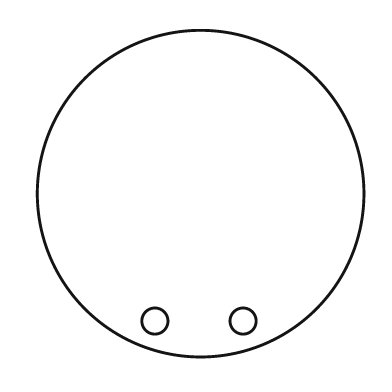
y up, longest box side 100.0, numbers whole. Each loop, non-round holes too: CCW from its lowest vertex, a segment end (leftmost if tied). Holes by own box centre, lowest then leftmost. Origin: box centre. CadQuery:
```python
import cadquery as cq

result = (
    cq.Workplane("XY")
    .moveTo(0.0, 0.0)
    .circle(50.0)
    .moveTo(-14.0, -39.0)
    .circle(4.0)
    .moveTo(13.0, -39.0)
    .circle(4.0)
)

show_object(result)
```